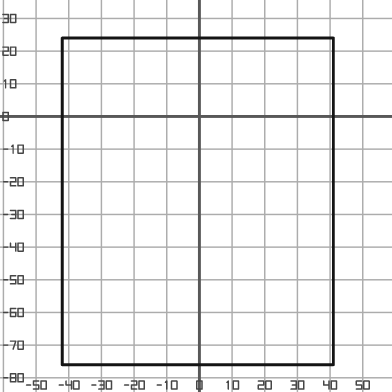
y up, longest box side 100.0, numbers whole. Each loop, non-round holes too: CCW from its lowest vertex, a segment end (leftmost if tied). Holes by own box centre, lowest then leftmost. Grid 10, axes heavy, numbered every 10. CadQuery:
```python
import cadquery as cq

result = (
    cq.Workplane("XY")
    .moveTo(-42.0, -76.0)
    .lineTo(41.0, -76.0)
    .lineTo(41.0, 24.0)
    .lineTo(-42.0, 24.0)
    .close()
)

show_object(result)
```